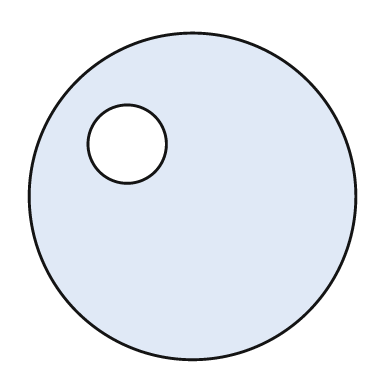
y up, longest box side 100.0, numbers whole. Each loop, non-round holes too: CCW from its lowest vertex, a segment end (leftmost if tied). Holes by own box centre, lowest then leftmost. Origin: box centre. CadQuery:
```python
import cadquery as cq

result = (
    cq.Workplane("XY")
    .moveTo(0.0, 0.0)
    .circle(50.0)
    .moveTo(-20.0, 16.0)
    .circle(12.0)
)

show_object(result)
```